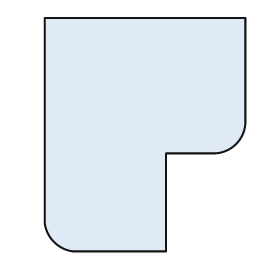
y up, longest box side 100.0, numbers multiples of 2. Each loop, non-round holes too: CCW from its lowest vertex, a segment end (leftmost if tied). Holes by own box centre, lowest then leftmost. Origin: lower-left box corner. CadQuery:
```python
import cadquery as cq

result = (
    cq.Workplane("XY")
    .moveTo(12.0, 0.0)
    .lineTo(52.0, 0.0)
    .lineTo(52.0, 42.0)
    .lineTo(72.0, 42.0)
    .threePointArc((82.0, 46.0), (86.0, 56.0))
    .lineTo(86.0, 100.0)
    .lineTo(0.0, 100.0)
    .lineTo(0.0, 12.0)
    .threePointArc((4.0, 4.0), (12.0, 0.0))
    .close()
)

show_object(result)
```